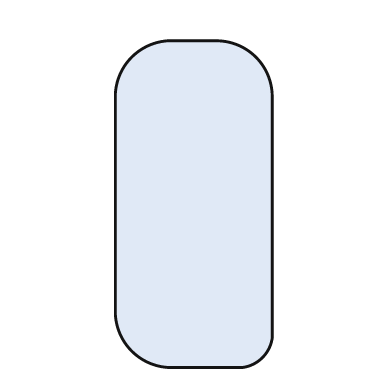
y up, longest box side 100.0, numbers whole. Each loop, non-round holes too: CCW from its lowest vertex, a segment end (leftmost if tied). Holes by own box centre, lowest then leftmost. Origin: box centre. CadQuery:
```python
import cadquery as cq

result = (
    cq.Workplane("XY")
    .moveTo(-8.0, -50.0)
    .lineTo(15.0, -50.0)
    .threePointArc((21.0, -47.0), (24.0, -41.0))
    .lineTo(24.0, 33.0)
    .threePointArc((19.0, 45.0), (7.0, 50.0))
    .lineTo(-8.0, 50.0)
    .threePointArc((-19.0, 45.0), (-24.0, 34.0))
    .lineTo(-24.0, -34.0)
    .threePointArc((-19.0, -45.0), (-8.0, -50.0))
    .close()
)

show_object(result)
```